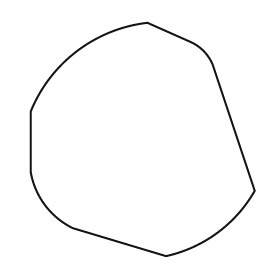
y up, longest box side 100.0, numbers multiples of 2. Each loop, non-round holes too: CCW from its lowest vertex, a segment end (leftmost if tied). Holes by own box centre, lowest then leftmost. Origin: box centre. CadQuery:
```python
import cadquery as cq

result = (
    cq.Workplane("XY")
    .moveTo(10.0, -50.0)
    .threePointArc((32.0, -40.0), (48.0, -22.0))
    .lineTo(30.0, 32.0)
    .threePointArc((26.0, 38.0), (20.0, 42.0))
    .lineTo(2.0, 50.0)
    .threePointArc((-28.0, 38.0), (-48.0, 12.0))
    .lineTo(-48.0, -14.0)
    .threePointArc((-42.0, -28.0), (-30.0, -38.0))
    .close()
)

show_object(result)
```